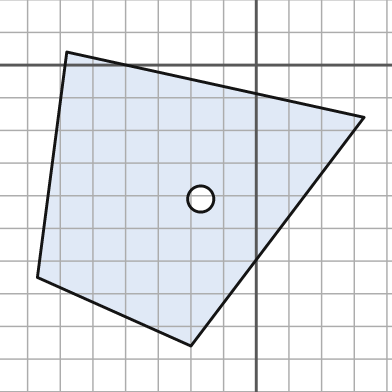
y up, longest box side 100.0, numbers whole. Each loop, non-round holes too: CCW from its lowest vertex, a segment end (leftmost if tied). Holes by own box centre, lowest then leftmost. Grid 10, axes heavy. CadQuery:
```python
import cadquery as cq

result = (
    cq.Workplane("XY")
    .moveTo(-20.0, -86.0)
    .lineTo(33.0, -16.0)
    .lineTo(-58.0, 4.0)
    .lineTo(-67.0, -65.0)
    .close()
    .moveTo(-17.0, -41.0)
    .circle(4.0)
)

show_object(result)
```